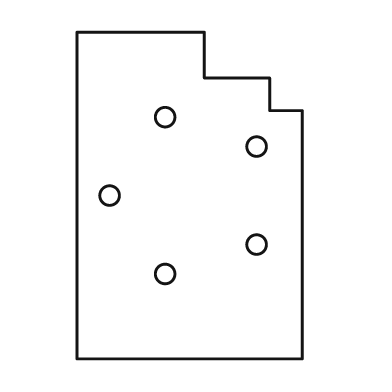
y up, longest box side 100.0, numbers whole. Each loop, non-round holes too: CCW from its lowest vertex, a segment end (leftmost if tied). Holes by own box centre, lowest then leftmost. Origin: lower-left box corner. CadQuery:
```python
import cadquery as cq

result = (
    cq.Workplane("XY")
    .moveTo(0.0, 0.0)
    .lineTo(69.0, 0.0)
    .lineTo(69.0, 76.0)
    .lineTo(59.0, 76.0)
    .lineTo(59.0, 86.0)
    .lineTo(39.0, 86.0)
    .lineTo(39.0, 100.0)
    .lineTo(0.0, 100.0)
    .close()
    .moveTo(27.0, 26.0)
    .circle(3.0)
    .moveTo(55.0, 35.0)
    .circle(3.0)
    .moveTo(10.0, 50.0)
    .circle(3.0)
    .moveTo(55.0, 65.0)
    .circle(3.0)
    .moveTo(27.0, 74.0)
    .circle(3.0)
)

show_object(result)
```